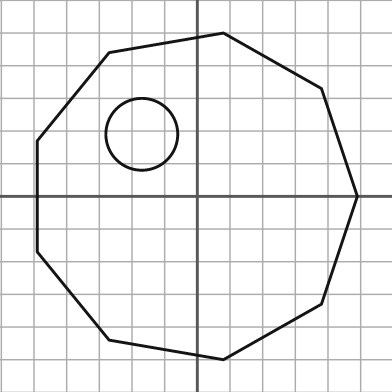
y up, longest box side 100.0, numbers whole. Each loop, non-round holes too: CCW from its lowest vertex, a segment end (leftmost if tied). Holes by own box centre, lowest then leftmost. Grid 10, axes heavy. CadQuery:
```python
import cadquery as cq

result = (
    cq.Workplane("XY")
    .moveTo(8.0, -50.0)
    .lineTo(38.0, -33.0)
    .lineTo(49.0, 0.0)
    .lineTo(38.0, 33.0)
    .lineTo(8.0, 50.0)
    .lineTo(-27.0, 44.0)
    .lineTo(-49.0, 17.0)
    .lineTo(-49.0, -17.0)
    .lineTo(-27.0, -44.0)
    .close()
    .moveTo(-17.0, 19.0)
    .circle(11.0)
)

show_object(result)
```